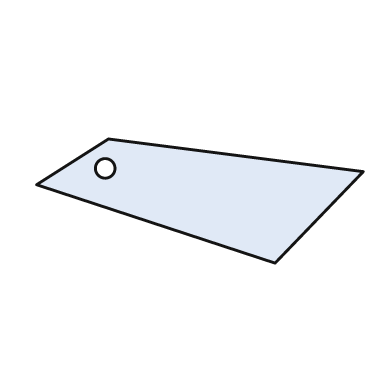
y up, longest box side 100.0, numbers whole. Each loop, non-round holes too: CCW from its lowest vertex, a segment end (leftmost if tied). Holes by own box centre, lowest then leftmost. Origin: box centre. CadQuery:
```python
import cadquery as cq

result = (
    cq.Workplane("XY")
    .moveTo(23.0, -19.0)
    .lineTo(50.0, 9.0)
    .lineTo(-28.0, 19.0)
    .lineTo(-50.0, 5.0)
    .close()
    .moveTo(-29.0, 10.0)
    .circle(3.0)
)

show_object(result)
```